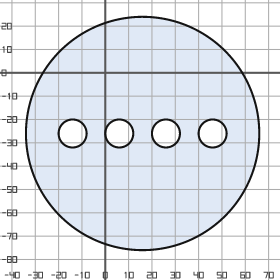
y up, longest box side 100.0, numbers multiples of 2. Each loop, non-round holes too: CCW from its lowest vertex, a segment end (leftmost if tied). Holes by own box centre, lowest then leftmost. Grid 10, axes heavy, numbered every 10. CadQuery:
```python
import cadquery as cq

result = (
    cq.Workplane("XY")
    .moveTo(16.0, -26.0)
    .circle(50.0)
    .moveTo(-14.0, -26.0)
    .circle(6.0)
    .moveTo(6.0, -26.0)
    .circle(6.0)
    .moveTo(26.0, -26.0)
    .circle(6.0)
    .moveTo(46.0, -26.0)
    .circle(6.0)
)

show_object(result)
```